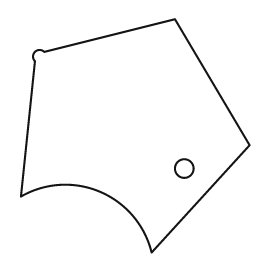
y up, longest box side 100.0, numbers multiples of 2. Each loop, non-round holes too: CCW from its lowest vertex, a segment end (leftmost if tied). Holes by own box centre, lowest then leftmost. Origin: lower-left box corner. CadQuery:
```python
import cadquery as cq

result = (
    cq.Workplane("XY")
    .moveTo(56.0, 0.0)
    .lineTo(98.0, 46.0)
    .lineTo(66.0, 100.0)
    .lineTo(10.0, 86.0)
    .threePointArc((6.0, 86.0), (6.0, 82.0))
    .lineTo(0.0, 24.0)
    .threePointArc((34.0, 26.0), (56.0, 0.0))
    .close()
    .moveTo(70.0, 36.0)
    .circle(4.0)
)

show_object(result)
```